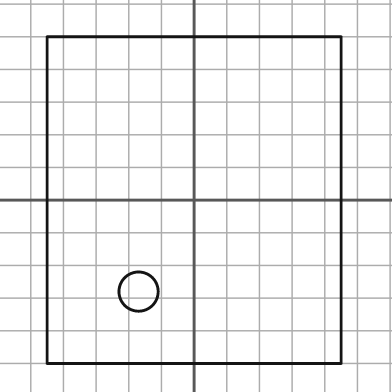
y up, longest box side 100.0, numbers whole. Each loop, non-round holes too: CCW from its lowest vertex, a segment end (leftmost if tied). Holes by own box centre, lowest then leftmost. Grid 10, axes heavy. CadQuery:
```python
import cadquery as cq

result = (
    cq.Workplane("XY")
    .moveTo(-45.0, -50.0)
    .lineTo(45.0, -50.0)
    .lineTo(45.0, 50.0)
    .lineTo(-45.0, 50.0)
    .close()
    .moveTo(-17.0, -28.0)
    .circle(6.0)
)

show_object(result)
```